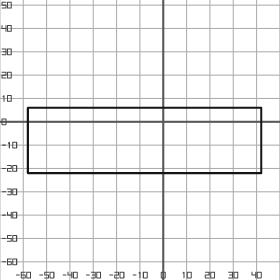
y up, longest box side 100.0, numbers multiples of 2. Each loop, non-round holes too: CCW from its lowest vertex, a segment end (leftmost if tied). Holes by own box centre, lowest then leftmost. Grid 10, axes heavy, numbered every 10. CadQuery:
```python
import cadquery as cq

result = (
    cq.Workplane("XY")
    .moveTo(-58.0, -22.0)
    .lineTo(42.0, -22.0)
    .lineTo(42.0, 6.0)
    .lineTo(-58.0, 6.0)
    .close()
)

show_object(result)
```